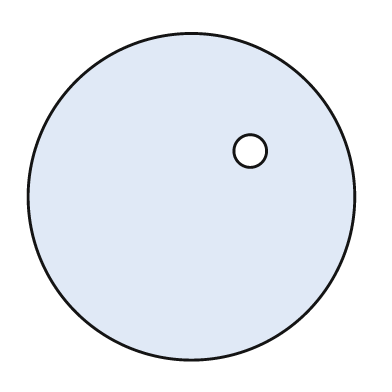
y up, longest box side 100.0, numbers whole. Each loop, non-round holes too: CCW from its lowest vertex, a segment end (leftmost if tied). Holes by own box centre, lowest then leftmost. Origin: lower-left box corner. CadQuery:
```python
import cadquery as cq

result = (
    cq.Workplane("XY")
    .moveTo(50.0, 50.0)
    .circle(50.0)
    .moveTo(68.0, 64.0)
    .circle(5.0)
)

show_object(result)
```